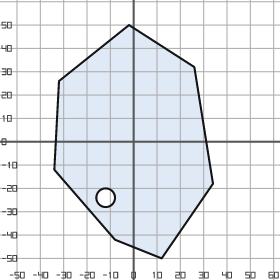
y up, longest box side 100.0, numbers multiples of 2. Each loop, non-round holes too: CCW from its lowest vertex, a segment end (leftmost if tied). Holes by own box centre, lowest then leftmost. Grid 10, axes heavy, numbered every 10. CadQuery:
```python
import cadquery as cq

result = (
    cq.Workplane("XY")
    .moveTo(12.0, -50.0)
    .lineTo(34.0, -18.0)
    .lineTo(26.0, 32.0)
    .lineTo(-2.0, 50.0)
    .lineTo(-32.0, 26.0)
    .lineTo(-34.0, -12.0)
    .lineTo(-8.0, -42.0)
    .close()
    .moveTo(-12.0, -24.0)
    .circle(4.0)
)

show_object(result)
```